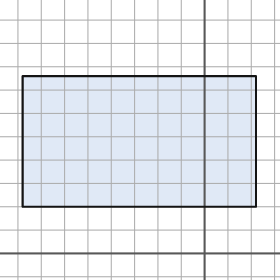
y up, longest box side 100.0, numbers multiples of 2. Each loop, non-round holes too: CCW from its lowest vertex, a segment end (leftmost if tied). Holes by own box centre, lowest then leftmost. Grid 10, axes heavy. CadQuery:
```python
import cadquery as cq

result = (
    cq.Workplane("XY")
    .moveTo(-78.0, 20.0)
    .lineTo(22.0, 20.0)
    .lineTo(22.0, 76.0)
    .lineTo(-78.0, 76.0)
    .close()
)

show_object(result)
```